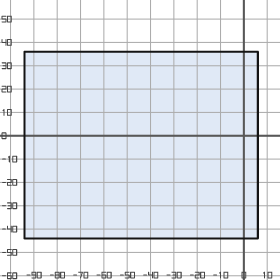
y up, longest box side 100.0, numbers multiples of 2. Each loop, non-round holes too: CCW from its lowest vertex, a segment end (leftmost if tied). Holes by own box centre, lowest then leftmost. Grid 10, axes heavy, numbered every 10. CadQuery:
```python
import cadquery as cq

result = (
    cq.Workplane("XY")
    .moveTo(-94.0, -44.0)
    .lineTo(6.0, -44.0)
    .lineTo(6.0, 36.0)
    .lineTo(-94.0, 36.0)
    .close()
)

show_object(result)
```